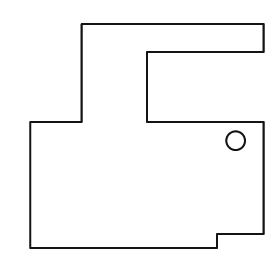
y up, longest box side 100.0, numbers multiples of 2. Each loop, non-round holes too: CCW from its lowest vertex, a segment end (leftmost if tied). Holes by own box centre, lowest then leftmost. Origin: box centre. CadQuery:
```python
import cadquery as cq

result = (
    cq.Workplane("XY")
    .moveTo(-50.0, -48.0)
    .lineTo(30.0, -48.0)
    .lineTo(30.0, -42.0)
    .lineTo(50.0, -42.0)
    .lineTo(50.0, 6.0)
    .lineTo(0.0, 6.0)
    .lineTo(0.0, 36.0)
    .lineTo(50.0, 36.0)
    .lineTo(50.0, 48.0)
    .lineTo(-28.0, 48.0)
    .lineTo(-28.0, 6.0)
    .lineTo(-50.0, 6.0)
    .close()
    .moveTo(38.0, -2.0)
    .circle(4.0)
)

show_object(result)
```